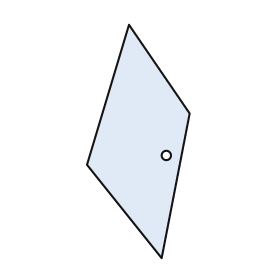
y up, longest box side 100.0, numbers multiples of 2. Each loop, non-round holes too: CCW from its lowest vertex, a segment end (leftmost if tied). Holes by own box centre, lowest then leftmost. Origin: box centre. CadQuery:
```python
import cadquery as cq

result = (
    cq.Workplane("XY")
    .moveTo(10.0, -50.0)
    .lineTo(22.0, 12.0)
    .lineTo(-4.0, 50.0)
    .lineTo(-22.0, -10.0)
    .close()
    .moveTo(12.0, -6.0)
    .circle(2.0)
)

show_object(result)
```